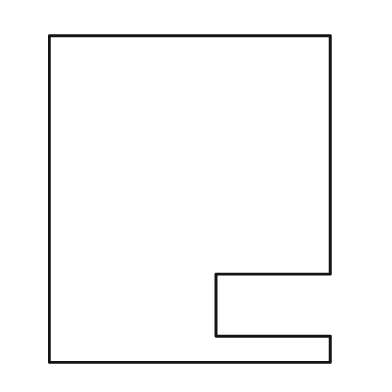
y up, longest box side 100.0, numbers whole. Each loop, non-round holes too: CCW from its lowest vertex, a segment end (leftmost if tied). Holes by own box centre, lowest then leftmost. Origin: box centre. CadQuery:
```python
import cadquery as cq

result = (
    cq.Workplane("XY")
    .moveTo(-43.0, -50.0)
    .lineTo(43.0, -50.0)
    .lineTo(43.0, -42.0)
    .lineTo(8.0, -42.0)
    .lineTo(8.0, -23.0)
    .lineTo(43.0, -23.0)
    .lineTo(43.0, 50.0)
    .lineTo(-43.0, 50.0)
    .close()
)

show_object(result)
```